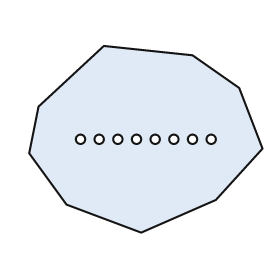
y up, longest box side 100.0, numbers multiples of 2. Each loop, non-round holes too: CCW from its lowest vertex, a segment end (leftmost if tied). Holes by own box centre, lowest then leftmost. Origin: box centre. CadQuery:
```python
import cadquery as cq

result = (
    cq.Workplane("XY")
    .moveTo(-2.0, -40.0)
    .lineTo(30.0, -26.0)
    .lineTo(50.0, -4.0)
    .lineTo(40.0, 22.0)
    .lineTo(20.0, 36.0)
    .lineTo(-18.0, 40.0)
    .lineTo(-46.0, 14.0)
    .lineTo(-50.0, -6.0)
    .lineTo(-34.0, -28.0)
    .close()
    .moveTo(-28.0, 0.0)
    .circle(2.0)
    .moveTo(-20.0, 0.0)
    .circle(2.0)
    .moveTo(-12.0, 0.0)
    .circle(2.0)
    .moveTo(-4.0, 0.0)
    .circle(2.0)
    .moveTo(4.0, 0.0)
    .circle(2.0)
    .moveTo(12.0, 0.0)
    .circle(2.0)
    .moveTo(20.0, 0.0)
    .circle(2.0)
    .moveTo(28.0, 0.0)
    .circle(2.0)
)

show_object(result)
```